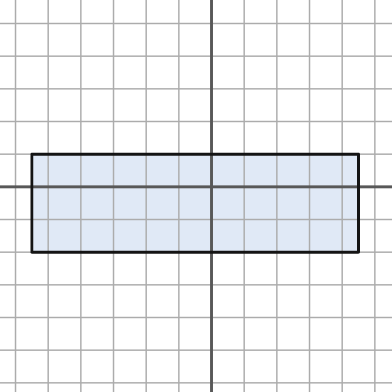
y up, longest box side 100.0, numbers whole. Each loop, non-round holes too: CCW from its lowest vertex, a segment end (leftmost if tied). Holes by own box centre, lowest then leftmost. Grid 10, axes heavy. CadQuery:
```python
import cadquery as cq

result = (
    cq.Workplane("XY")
    .moveTo(-55.0, -20.0)
    .lineTo(45.0, -20.0)
    .lineTo(45.0, 10.0)
    .lineTo(-55.0, 10.0)
    .close()
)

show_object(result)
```